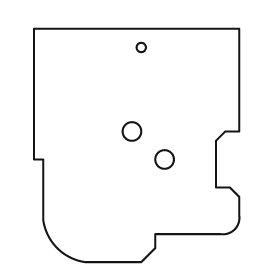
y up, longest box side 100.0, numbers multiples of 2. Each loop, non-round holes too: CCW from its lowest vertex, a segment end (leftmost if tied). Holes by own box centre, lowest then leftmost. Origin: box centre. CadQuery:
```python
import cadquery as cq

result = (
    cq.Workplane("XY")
    .moveTo(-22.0, -50.0)
    .lineTo(2.0, -50.0)
    .lineTo(8.0, -44.0)
    .lineTo(8.0, -38.0)
    .lineTo(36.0, -38.0)
    .threePointArc((42.0, -36.0), (44.0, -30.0))
    .lineTo(44.0, -22.0)
    .lineTo(40.0, -18.0)
    .lineTo(34.0, -18.0)
    .lineTo(34.0, 2.0)
    .lineTo(38.0, 6.0)
    .lineTo(44.0, 6.0)
    .lineTo(44.0, 50.0)
    .lineTo(-44.0, 50.0)
    .lineTo(-44.0, -6.0)
    .lineTo(-40.0, -6.0)
    .lineTo(-40.0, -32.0)
    .threePointArc((-34.0, -44.0), (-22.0, -50.0))
    .close()
    .moveTo(12.0, -6.0)
    .circle(4.0)
    .moveTo(-2.0, 6.0)
    .circle(4.0)
    .moveTo(2.0, 42.0)
    .circle(2.0)
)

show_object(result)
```